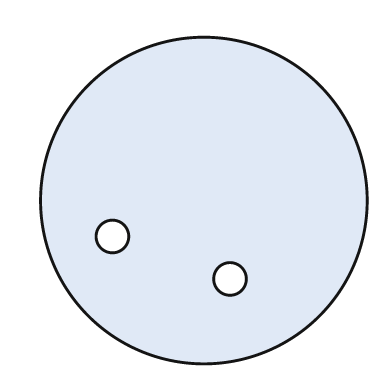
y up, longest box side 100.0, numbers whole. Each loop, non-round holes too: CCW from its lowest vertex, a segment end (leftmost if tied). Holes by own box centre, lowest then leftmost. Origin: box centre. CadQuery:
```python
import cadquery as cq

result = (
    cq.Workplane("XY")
    .moveTo(0.0, 0.0)
    .circle(50.0)
    .moveTo(8.0, -24.0)
    .circle(5.0)
    .moveTo(-28.0, -11.0)
    .circle(5.0)
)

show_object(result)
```